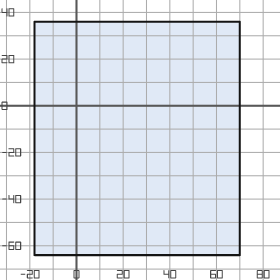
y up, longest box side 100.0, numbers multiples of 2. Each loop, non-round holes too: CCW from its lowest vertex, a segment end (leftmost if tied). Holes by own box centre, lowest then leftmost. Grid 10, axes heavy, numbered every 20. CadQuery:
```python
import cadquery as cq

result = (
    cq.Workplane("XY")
    .moveTo(-18.0, -64.0)
    .lineTo(70.0, -64.0)
    .lineTo(70.0, 36.0)
    .lineTo(-18.0, 36.0)
    .close()
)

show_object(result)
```